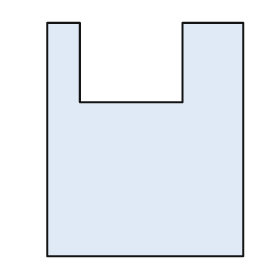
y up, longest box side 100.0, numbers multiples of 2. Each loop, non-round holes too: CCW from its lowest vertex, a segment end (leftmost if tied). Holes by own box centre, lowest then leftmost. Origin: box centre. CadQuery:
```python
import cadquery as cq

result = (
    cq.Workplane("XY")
    .moveTo(-42.0, -50.0)
    .lineTo(42.0, -50.0)
    .lineTo(42.0, 50.0)
    .lineTo(16.0, 50.0)
    .lineTo(16.0, 16.0)
    .lineTo(-28.0, 16.0)
    .lineTo(-28.0, 50.0)
    .lineTo(-42.0, 50.0)
    .close()
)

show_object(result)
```